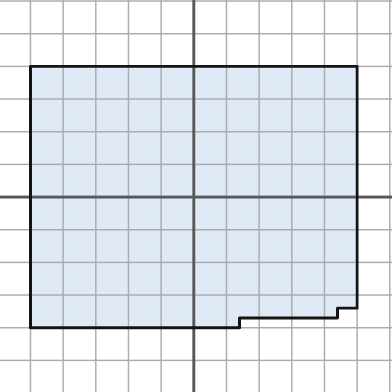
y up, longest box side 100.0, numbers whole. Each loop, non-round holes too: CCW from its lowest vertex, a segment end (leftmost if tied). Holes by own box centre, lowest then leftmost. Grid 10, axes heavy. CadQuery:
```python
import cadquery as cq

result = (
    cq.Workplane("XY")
    .moveTo(-50.0, -40.0)
    .lineTo(14.0, -40.0)
    .lineTo(14.0, -37.0)
    .lineTo(44.0, -37.0)
    .lineTo(44.0, -34.0)
    .lineTo(50.0, -34.0)
    .lineTo(50.0, 40.0)
    .lineTo(-50.0, 40.0)
    .close()
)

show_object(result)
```